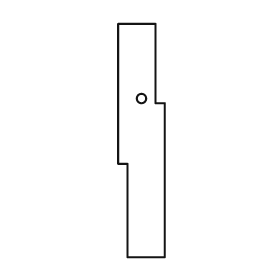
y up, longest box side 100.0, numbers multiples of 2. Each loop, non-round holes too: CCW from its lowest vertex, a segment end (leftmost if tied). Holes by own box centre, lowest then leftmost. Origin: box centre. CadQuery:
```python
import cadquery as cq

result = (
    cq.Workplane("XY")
    .moveTo(-6.0, -50.0)
    .lineTo(10.0, -50.0)
    .lineTo(10.0, 16.0)
    .lineTo(6.0, 16.0)
    .lineTo(6.0, 50.0)
    .lineTo(-10.0, 50.0)
    .lineTo(-10.0, -10.0)
    .lineTo(-6.0, -10.0)
    .close()
    .moveTo(0.0, 18.0)
    .circle(2.0)
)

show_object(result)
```